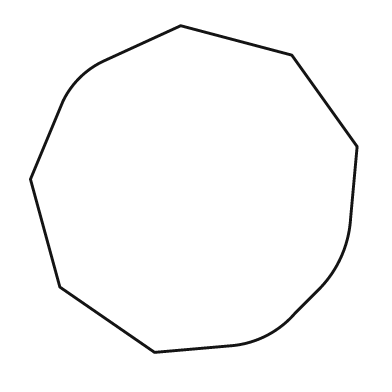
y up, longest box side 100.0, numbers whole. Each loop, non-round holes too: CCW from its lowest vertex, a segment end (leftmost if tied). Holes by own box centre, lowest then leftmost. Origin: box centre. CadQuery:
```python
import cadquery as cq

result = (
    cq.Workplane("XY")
    .moveTo(-12.0, -50.0)
    .lineTo(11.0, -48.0)
    .threePointArc((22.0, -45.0), (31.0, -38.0))
    .lineTo(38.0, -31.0)
    .threePointArc((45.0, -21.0), (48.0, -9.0))
    .lineTo(50.0, 13.0)
    .lineTo(30.0, 41.0)
    .lineTo(-4.0, 50.0)
    .lineTo(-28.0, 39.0)
    .threePointArc((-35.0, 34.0), (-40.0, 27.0))
    .lineTo(-50.0, 3.0)
    .lineTo(-41.0, -30.0)
    .close()
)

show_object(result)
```